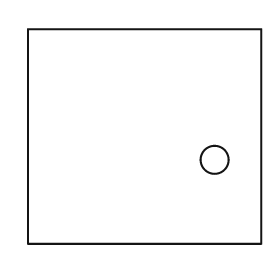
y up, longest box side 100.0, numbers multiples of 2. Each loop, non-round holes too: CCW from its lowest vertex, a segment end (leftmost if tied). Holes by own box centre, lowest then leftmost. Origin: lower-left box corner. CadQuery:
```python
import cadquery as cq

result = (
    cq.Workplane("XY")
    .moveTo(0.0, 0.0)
    .lineTo(100.0, 0.0)
    .lineTo(100.0, 92.0)
    .lineTo(0.0, 92.0)
    .close()
    .moveTo(80.0, 36.0)
    .circle(6.0)
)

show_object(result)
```